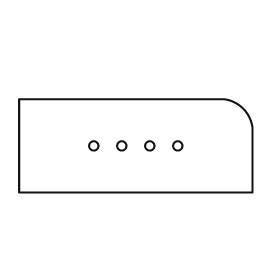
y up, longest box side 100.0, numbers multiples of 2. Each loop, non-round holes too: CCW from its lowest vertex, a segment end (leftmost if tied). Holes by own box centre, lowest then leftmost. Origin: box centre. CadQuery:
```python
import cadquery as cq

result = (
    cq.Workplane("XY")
    .moveTo(-50.0, -20.0)
    .lineTo(50.0, -20.0)
    .lineTo(50.0, 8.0)
    .threePointArc((46.0, 16.0), (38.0, 20.0))
    .lineTo(-50.0, 20.0)
    .close()
    .moveTo(-18.0, 0.0)
    .circle(2.0)
    .moveTo(-6.0, 0.0)
    .circle(2.0)
    .moveTo(6.0, 0.0)
    .circle(2.0)
    .moveTo(18.0, 0.0)
    .circle(2.0)
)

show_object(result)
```